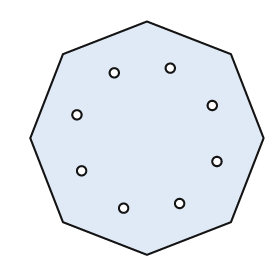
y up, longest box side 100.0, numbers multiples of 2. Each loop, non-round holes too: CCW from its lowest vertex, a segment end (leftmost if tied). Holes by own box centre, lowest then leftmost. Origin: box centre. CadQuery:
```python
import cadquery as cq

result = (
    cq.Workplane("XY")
    .moveTo(0.0, -50.0)
    .lineTo(36.0, -36.0)
    .lineTo(50.0, 0.0)
    .lineTo(36.0, 36.0)
    .lineTo(0.0, 50.0)
    .lineTo(-36.0, 36.0)
    .lineTo(-50.0, 0.0)
    .lineTo(-36.0, -36.0)
    .close()
    .moveTo(-10.0, -30.0)
    .circle(2.0)
    .moveTo(14.0, -28.0)
    .circle(2.0)
    .moveTo(-28.0, -14.0)
    .circle(2.0)
    .moveTo(30.0, -10.0)
    .circle(2.0)
    .moveTo(-30.0, 10.0)
    .circle(2.0)
    .moveTo(28.0, 14.0)
    .circle(2.0)
    .moveTo(-14.0, 28.0)
    .circle(2.0)
    .moveTo(10.0, 30.0)
    .circle(2.0)
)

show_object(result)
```